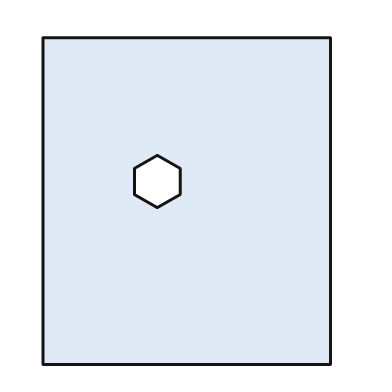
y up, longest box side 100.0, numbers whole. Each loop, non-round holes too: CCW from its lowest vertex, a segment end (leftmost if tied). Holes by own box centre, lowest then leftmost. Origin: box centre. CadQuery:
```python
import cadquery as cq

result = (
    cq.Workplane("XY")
    .moveTo(-44.0, -50.0)
    .lineTo(44.0, -50.0)
    .lineTo(44.0, 50.0)
    .lineTo(-44.0, 50.0)
    .close()
    .moveTo(-9.0, -2.0)
    .lineTo(-2.0, 2.0)
    .lineTo(-2.0, 10.0)
    .lineTo(-9.0, 14.0)
    .lineTo(-16.0, 10.0)
    .lineTo(-16.0, 2.0)
    .close()
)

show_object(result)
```